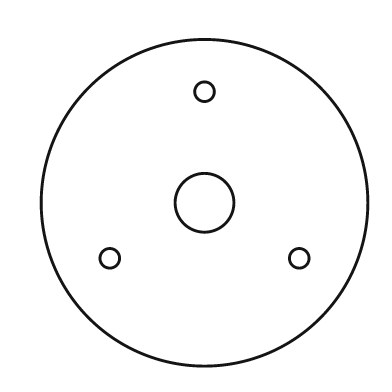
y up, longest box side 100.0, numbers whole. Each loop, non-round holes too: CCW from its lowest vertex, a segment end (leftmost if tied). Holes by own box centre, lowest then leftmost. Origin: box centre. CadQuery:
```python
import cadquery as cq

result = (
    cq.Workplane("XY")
    .moveTo(0.0, 0.0)
    .circle(50.0)
    .moveTo(-29.0, -17.0)
    .circle(3.0)
    .moveTo(29.0, -17.0)
    .circle(3.0)
    .moveTo(0.0, 0.0)
    .circle(9.0)
    .moveTo(0.0, 34.0)
    .circle(3.0)
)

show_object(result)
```